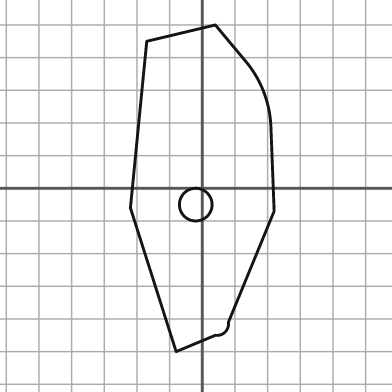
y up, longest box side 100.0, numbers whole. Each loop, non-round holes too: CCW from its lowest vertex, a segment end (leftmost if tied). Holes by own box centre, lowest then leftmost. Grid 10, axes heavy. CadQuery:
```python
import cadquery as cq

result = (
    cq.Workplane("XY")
    .moveTo(-8.0, -50.0)
    .lineTo(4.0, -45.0)
    .threePointArc((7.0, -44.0), (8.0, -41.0))
    .lineTo(22.0, -7.0)
    .lineTo(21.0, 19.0)
    .threePointArc((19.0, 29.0), (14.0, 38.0))
    .lineTo(4.0, 50.0)
    .lineTo(-17.0, 45.0)
    .lineTo(-22.0, -6.0)
    .close()
    .moveTo(-2.0, -5.0)
    .circle(5.0)
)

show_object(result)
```